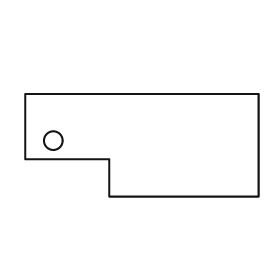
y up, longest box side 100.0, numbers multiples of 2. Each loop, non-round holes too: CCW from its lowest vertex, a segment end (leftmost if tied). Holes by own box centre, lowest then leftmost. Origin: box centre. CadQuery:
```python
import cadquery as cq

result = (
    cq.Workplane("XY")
    .moveTo(-14.0, -22.0)
    .lineTo(50.0, -22.0)
    .lineTo(50.0, 22.0)
    .lineTo(-50.0, 22.0)
    .lineTo(-50.0, -6.0)
    .lineTo(-14.0, -6.0)
    .close()
    .moveTo(-38.0, 2.0)
    .circle(4.0)
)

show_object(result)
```